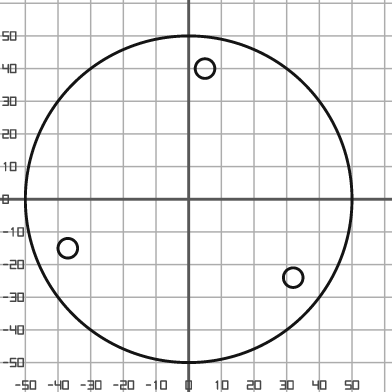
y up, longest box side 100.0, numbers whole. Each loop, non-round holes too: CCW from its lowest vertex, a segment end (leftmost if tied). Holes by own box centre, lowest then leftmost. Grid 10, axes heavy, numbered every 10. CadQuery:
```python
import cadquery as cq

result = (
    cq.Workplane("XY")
    .moveTo(0.0, 0.0)
    .circle(50.0)
    .moveTo(32.0, -24.0)
    .circle(3.0)
    .moveTo(-37.0, -15.0)
    .circle(3.0)
    .moveTo(5.0, 40.0)
    .circle(3.0)
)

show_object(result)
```